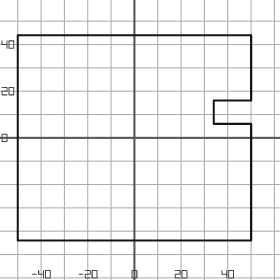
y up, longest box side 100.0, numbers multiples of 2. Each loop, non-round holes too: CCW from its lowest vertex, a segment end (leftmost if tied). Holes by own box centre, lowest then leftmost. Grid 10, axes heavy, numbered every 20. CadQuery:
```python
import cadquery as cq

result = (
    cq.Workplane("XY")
    .moveTo(-50.0, -44.0)
    .lineTo(50.0, -44.0)
    .lineTo(50.0, 6.0)
    .lineTo(34.0, 6.0)
    .lineTo(34.0, 16.0)
    .lineTo(50.0, 16.0)
    .lineTo(50.0, 44.0)
    .lineTo(-50.0, 44.0)
    .close()
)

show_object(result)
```